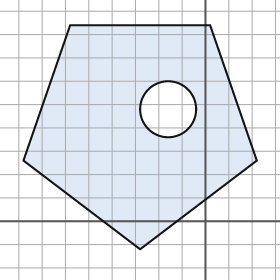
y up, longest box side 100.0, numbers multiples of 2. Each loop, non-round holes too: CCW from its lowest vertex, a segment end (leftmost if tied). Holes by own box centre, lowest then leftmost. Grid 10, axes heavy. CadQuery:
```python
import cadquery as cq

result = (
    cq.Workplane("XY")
    .moveTo(-28.0, -12.0)
    .lineTo(22.0, 26.0)
    .lineTo(2.0, 84.0)
    .lineTo(-58.0, 84.0)
    .lineTo(-78.0, 26.0)
    .close()
    .moveTo(-16.0, 48.0)
    .circle(12.0)
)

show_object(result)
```